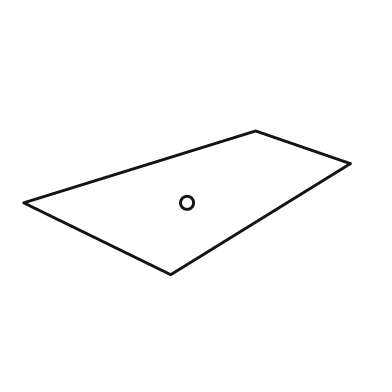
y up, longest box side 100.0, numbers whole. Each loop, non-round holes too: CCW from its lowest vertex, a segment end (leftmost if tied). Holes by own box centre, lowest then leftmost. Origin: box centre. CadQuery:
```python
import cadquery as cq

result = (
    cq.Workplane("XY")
    .moveTo(-5.0, -22.0)
    .lineTo(50.0, 12.0)
    .lineTo(21.0, 22.0)
    .lineTo(-50.0, 0.0)
    .close()
    .moveTo(0.0, 0.0)
    .circle(2.0)
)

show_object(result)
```